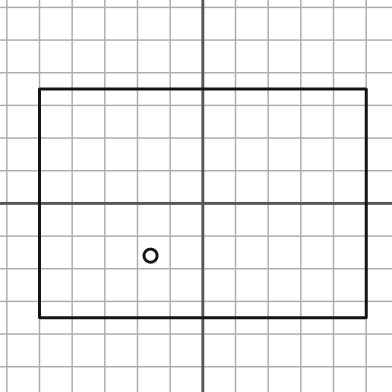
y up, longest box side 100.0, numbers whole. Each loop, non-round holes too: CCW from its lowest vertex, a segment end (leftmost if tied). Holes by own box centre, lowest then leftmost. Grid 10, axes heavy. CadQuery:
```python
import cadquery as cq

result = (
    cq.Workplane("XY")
    .moveTo(-50.0, -35.0)
    .lineTo(50.0, -35.0)
    .lineTo(50.0, 35.0)
    .lineTo(-50.0, 35.0)
    .close()
    .moveTo(-16.0, -16.0)
    .circle(2.0)
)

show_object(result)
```